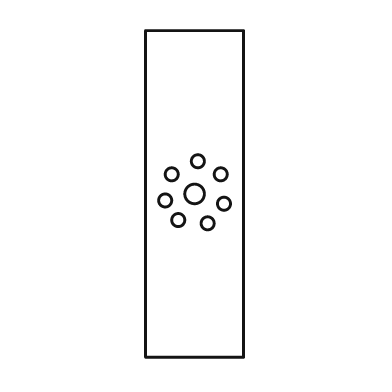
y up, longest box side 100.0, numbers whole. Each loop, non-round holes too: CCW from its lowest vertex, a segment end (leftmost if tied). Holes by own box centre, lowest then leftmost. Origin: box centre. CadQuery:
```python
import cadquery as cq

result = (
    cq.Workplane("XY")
    .moveTo(-15.0, -50.0)
    .lineTo(15.0, -50.0)
    .lineTo(15.0, 50.0)
    .lineTo(-15.0, 50.0)
    .close()
    .moveTo(4.0, -9.0)
    .circle(2.0)
    .moveTo(-5.0, -8.0)
    .circle(2.0)
    .moveTo(9.0, -3.0)
    .circle(2.0)
    .moveTo(-9.0, -2.0)
    .circle(2.0)
    .moveTo(0.0, 0.0)
    .circle(3.0)
    .moveTo(-7.0, 6.0)
    .circle(2.0)
    .moveTo(8.0, 6.0)
    .circle(2.0)
    .moveTo(1.0, 10.0)
    .circle(2.0)
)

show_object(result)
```